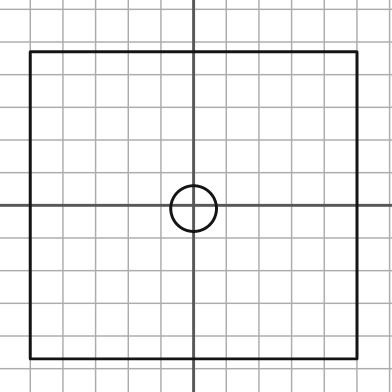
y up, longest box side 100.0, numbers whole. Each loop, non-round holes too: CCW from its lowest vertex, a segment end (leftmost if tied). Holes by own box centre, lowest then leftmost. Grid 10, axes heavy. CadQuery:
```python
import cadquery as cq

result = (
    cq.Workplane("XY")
    .moveTo(-50.0, -47.0)
    .lineTo(50.0, -47.0)
    .lineTo(50.0, 47.0)
    .lineTo(-50.0, 47.0)
    .close()
    .moveTo(0.0, -1.0)
    .circle(7.0)
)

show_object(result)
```